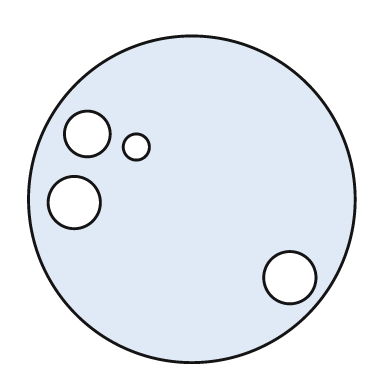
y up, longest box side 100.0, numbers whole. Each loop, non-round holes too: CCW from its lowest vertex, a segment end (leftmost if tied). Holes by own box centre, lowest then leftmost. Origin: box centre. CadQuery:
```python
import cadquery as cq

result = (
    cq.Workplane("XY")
    .moveTo(0.0, 0.0)
    .circle(50.0)
    .moveTo(30.0, -24.0)
    .circle(8.0)
    .moveTo(-36.0, -1.0)
    .circle(8.0)
    .moveTo(-17.0, 16.0)
    .circle(4.0)
    .moveTo(-32.0, 20.0)
    .circle(7.0)
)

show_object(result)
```